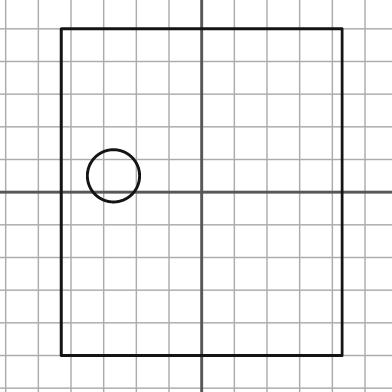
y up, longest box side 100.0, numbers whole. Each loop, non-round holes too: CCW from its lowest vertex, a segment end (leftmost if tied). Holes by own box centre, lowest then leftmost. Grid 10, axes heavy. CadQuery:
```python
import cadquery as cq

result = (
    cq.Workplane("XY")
    .moveTo(-43.0, -50.0)
    .lineTo(43.0, -50.0)
    .lineTo(43.0, 50.0)
    .lineTo(-43.0, 50.0)
    .close()
    .moveTo(-27.0, 5.0)
    .circle(8.0)
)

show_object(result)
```